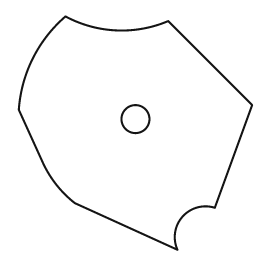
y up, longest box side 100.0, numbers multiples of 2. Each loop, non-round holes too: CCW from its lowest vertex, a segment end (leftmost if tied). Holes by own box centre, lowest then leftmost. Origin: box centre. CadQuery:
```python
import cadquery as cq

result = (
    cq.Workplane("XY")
    .moveTo(18.0, -50.0)
    .threePointArc((20.0, -36.0), (34.0, -32.0))
    .lineTo(50.0, 12.0)
    .lineTo(14.0, 48.0)
    .threePointArc((-8.0, 44.0), (-30.0, 50.0))
    .threePointArc((-44.0, 32.0), (-50.0, 10.0))
    .lineTo(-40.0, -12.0)
    .threePointArc((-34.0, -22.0), (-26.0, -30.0))
    .close()
    .moveTo(0.0, 6.0)
    .circle(6.0)
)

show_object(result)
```